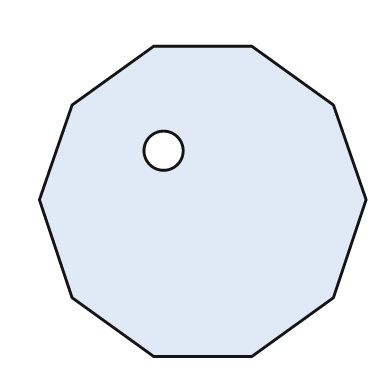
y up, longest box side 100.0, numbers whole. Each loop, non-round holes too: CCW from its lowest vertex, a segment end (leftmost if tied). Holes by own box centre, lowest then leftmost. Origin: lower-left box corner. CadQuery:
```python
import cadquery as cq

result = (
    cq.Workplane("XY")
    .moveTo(35.0, 0.0)
    .lineTo(65.0, 0.0)
    .lineTo(90.0, 18.0)
    .lineTo(100.0, 48.0)
    .lineTo(90.0, 77.0)
    .lineTo(65.0, 95.0)
    .lineTo(35.0, 95.0)
    .lineTo(10.0, 77.0)
    .lineTo(0.0, 48.0)
    .lineTo(10.0, 18.0)
    .close()
    .moveTo(38.0, 63.0)
    .circle(6.0)
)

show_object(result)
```